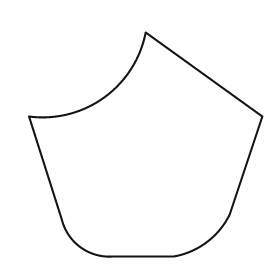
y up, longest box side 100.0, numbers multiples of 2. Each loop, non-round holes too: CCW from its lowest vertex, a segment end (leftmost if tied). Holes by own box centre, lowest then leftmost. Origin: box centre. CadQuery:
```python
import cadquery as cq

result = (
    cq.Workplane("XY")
    .moveTo(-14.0, -48.0)
    .lineTo(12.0, -48.0)
    .threePointArc((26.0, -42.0), (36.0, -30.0))
    .lineTo(50.0, 12.0)
    .lineTo(0.0, 48.0)
    .threePointArc((-18.0, 20.0), (-50.0, 12.0))
    .lineTo(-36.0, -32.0)
    .threePointArc((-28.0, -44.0), (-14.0, -48.0))
    .close()
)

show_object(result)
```